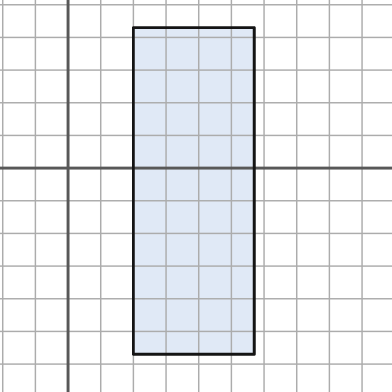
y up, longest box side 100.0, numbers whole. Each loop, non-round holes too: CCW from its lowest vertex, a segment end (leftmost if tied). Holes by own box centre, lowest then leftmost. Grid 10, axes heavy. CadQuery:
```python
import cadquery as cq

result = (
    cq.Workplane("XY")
    .moveTo(20.0, -57.0)
    .lineTo(57.0, -57.0)
    .lineTo(57.0, 43.0)
    .lineTo(20.0, 43.0)
    .close()
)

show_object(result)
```